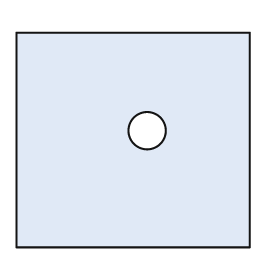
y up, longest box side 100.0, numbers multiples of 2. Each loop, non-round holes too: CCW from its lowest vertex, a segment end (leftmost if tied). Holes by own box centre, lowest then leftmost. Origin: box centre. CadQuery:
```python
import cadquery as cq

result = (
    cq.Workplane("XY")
    .moveTo(-50.0, -46.0)
    .lineTo(50.0, -46.0)
    .lineTo(50.0, 46.0)
    .lineTo(-50.0, 46.0)
    .close()
    .moveTo(6.0, 4.0)
    .circle(8.0)
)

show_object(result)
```